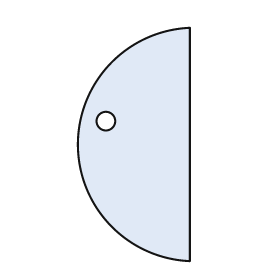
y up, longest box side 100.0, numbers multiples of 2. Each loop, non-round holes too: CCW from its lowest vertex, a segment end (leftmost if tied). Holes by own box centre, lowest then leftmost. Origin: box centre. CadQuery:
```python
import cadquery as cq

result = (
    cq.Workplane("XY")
    .moveTo(24.0, -50.0)
    .lineTo(24.0, 50.0)
    .threePointArc((-24.0, 0.0), (24.0, -50.0))
    .close()
    .moveTo(-12.0, 10.0)
    .circle(4.0)
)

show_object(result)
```